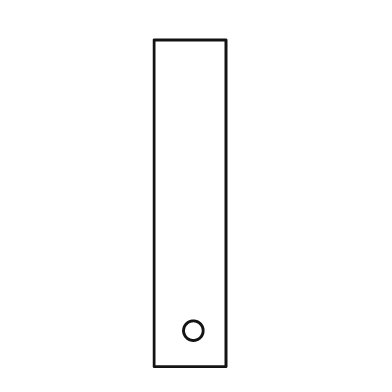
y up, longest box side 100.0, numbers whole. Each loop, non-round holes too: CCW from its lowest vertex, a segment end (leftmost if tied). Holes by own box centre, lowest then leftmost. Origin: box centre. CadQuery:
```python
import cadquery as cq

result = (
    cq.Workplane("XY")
    .moveTo(-11.0, -50.0)
    .lineTo(11.0, -50.0)
    .lineTo(11.0, 50.0)
    .lineTo(-11.0, 50.0)
    .close()
    .moveTo(1.0, -39.0)
    .circle(3.0)
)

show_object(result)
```